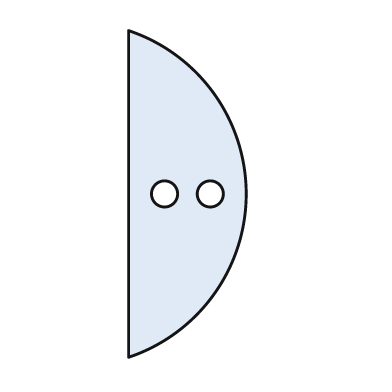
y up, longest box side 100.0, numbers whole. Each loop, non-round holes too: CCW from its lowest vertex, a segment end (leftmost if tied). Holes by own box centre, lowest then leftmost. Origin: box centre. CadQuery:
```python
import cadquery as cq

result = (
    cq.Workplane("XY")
    .moveTo(-18.0, -50.0)
    .threePointArc((18.0, 0.0), (-18.0, 50.0))
    .close()
    .moveTo(-7.0, 0.0)
    .circle(4.0)
    .moveTo(7.0, 0.0)
    .circle(4.0)
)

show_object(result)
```